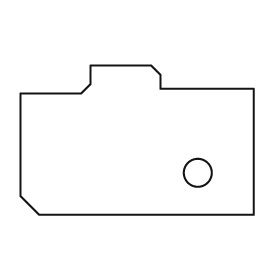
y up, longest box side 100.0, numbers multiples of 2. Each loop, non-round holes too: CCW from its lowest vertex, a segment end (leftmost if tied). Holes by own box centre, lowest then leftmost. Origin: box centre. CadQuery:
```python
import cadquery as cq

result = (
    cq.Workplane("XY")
    .moveTo(-42.0, -32.0)
    .lineTo(50.0, -32.0)
    .lineTo(50.0, 22.0)
    .lineTo(10.0, 22.0)
    .lineTo(10.0, 28.0)
    .lineTo(6.0, 32.0)
    .lineTo(-20.0, 32.0)
    .lineTo(-20.0, 24.0)
    .lineTo(-24.0, 20.0)
    .lineTo(-50.0, 20.0)
    .lineTo(-50.0, -24.0)
    .close()
    .moveTo(26.0, -14.0)
    .circle(6.0)
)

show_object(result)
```